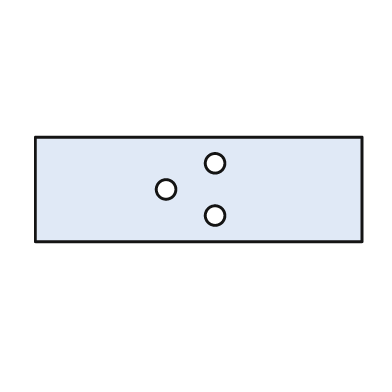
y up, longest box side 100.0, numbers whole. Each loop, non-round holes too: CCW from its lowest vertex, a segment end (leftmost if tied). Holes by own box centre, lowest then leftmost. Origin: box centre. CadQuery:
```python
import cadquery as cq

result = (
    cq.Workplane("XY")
    .moveTo(-50.0, -16.0)
    .lineTo(50.0, -16.0)
    .lineTo(50.0, 16.0)
    .lineTo(-50.0, 16.0)
    .close()
    .moveTo(5.0, -8.0)
    .circle(3.0)
    .moveTo(-10.0, 0.0)
    .circle(3.0)
    .moveTo(5.0, 8.0)
    .circle(3.0)
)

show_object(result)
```